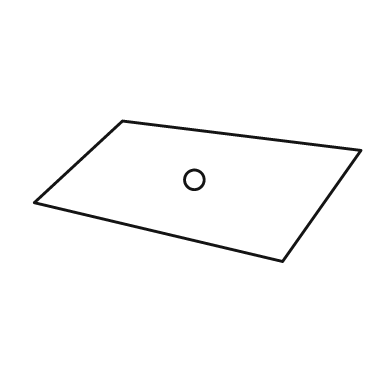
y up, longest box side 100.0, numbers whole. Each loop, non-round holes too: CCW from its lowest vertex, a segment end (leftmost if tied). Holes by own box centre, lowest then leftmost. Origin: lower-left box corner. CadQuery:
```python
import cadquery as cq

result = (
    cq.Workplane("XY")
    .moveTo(76.0, 0.0)
    .lineTo(100.0, 34.0)
    .lineTo(27.0, 43.0)
    .lineTo(0.0, 18.0)
    .close()
    .moveTo(49.0, 25.0)
    .circle(3.0)
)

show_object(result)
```